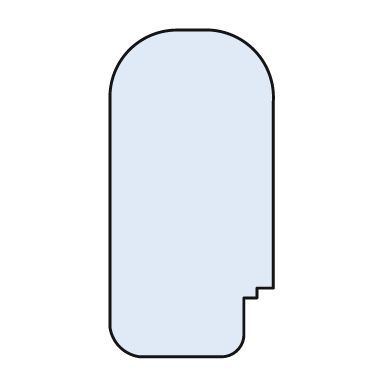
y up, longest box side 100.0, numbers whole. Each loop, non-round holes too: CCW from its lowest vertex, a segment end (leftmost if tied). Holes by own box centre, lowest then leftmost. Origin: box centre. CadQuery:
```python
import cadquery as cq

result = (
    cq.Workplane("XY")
    .moveTo(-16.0, -50.0)
    .lineTo(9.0, -50.0)
    .threePointArc((14.0, -48.0), (16.0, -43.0))
    .lineTo(16.0, -32.0)
    .lineTo(20.0, -32.0)
    .lineTo(20.0, -29.0)
    .lineTo(25.0, -29.0)
    .lineTo(25.0, 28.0)
    .threePointArc((19.0, 44.0), (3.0, 50.0))
    .lineTo(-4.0, 50.0)
    .threePointArc((-19.0, 44.0), (-25.0, 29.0))
    .lineTo(-25.0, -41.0)
    .threePointArc((-22.0, -47.0), (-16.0, -50.0))
    .close()
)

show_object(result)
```